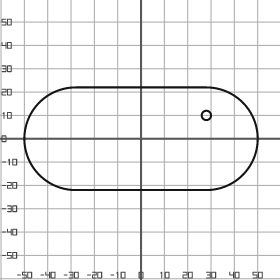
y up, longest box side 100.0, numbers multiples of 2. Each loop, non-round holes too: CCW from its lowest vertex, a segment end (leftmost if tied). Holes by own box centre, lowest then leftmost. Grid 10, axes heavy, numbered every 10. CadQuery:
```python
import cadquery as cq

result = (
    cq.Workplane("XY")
    .moveTo(-28.0, -22.0)
    .lineTo(28.0, -22.0)
    .threePointArc((50.0, 0.0), (28.0, 22.0))
    .lineTo(-28.0, 22.0)
    .threePointArc((-50.0, 0.0), (-28.0, -22.0))
    .close()
    .moveTo(28.0, 10.0)
    .circle(2.0)
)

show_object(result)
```